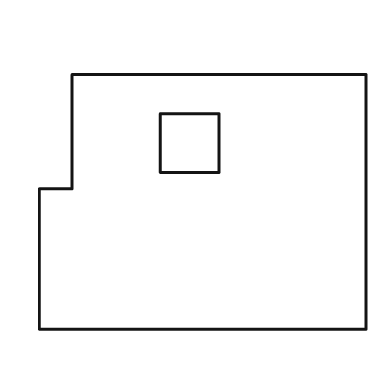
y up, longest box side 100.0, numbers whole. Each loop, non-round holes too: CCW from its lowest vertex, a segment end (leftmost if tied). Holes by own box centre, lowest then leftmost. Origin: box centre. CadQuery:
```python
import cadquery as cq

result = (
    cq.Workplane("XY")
    .moveTo(-50.0, -39.0)
    .lineTo(50.0, -39.0)
    .lineTo(50.0, 39.0)
    .lineTo(-40.0, 39.0)
    .lineTo(-40.0, 4.0)
    .lineTo(-50.0, 4.0)
    .close()
    .moveTo(-13.0, 9.0)
    .lineTo(5.0, 9.0)
    .lineTo(5.0, 27.0)
    .lineTo(-13.0, 27.0)
    .close()
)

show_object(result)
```